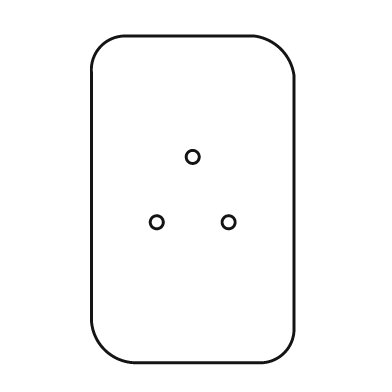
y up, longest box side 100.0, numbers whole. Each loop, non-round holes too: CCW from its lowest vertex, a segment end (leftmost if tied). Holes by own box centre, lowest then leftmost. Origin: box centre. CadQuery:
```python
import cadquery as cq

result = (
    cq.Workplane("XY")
    .moveTo(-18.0, -50.0)
    .lineTo(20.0, -50.0)
    .threePointArc((28.0, -47.0), (31.0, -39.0))
    .lineTo(31.0, 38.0)
    .threePointArc((27.0, 46.0), (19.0, 50.0))
    .lineTo(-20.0, 50.0)
    .threePointArc((-28.0, 47.0), (-31.0, 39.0))
    .lineTo(-31.0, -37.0)
    .threePointArc((-27.0, -46.0), (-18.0, -50.0))
    .close()
    .moveTo(-11.0, -7.0)
    .circle(2.0)
    .moveTo(11.0, -7.0)
    .circle(2.0)
    .moveTo(0.0, 13.0)
    .circle(2.0)
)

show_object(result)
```